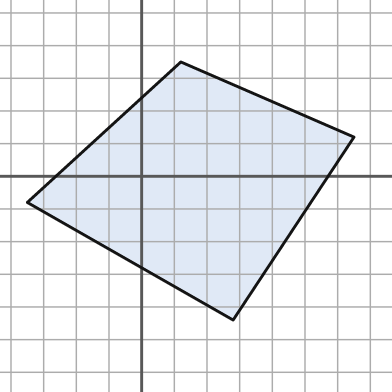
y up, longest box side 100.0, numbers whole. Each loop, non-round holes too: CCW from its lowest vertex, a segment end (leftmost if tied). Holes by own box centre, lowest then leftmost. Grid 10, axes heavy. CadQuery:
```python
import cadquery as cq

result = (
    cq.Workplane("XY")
    .moveTo(28.0, -44.0)
    .lineTo(65.0, 12.0)
    .lineTo(12.0, 35.0)
    .lineTo(-35.0, -8.0)
    .close()
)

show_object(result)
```